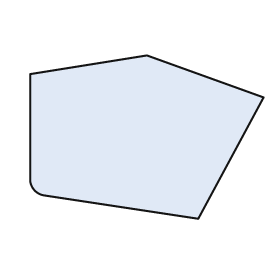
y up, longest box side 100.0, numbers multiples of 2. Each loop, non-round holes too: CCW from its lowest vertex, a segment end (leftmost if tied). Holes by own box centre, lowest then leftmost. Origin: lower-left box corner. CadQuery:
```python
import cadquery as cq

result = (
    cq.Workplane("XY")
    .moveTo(72.0, 0.0)
    .lineTo(100.0, 52.0)
    .lineTo(50.0, 70.0)
    .lineTo(0.0, 62.0)
    .lineTo(0.0, 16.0)
    .threePointArc((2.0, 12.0), (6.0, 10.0))
    .close()
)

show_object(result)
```